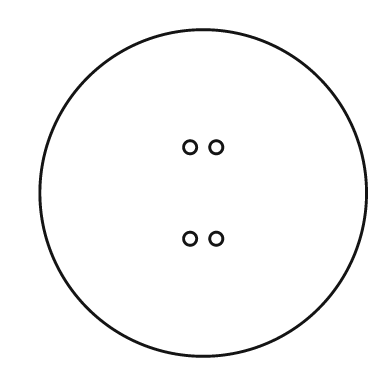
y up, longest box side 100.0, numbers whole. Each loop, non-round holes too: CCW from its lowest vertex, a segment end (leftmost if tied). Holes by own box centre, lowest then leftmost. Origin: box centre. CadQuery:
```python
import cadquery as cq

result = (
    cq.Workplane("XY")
    .moveTo(0.0, 0.0)
    .circle(50.0)
    .moveTo(-4.0, -14.0)
    .circle(2.0)
    .moveTo(4.0, -14.0)
    .circle(2.0)
    .moveTo(-4.0, 14.0)
    .circle(2.0)
    .moveTo(4.0, 14.0)
    .circle(2.0)
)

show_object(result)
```